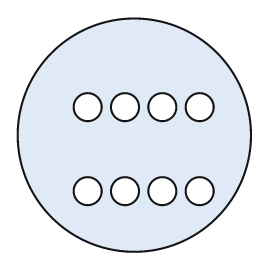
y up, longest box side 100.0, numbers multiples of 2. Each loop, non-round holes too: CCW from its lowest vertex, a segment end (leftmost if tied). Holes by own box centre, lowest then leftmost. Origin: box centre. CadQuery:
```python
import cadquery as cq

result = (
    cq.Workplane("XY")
    .moveTo(0.0, 0.0)
    .circle(50.0)
    .moveTo(-20.0, -24.0)
    .circle(6.0)
    .moveTo(-4.0, -24.0)
    .circle(6.0)
    .moveTo(12.0, -24.0)
    .circle(6.0)
    .moveTo(28.0, -24.0)
    .circle(6.0)
    .moveTo(-20.0, 12.0)
    .circle(6.0)
    .moveTo(-4.0, 12.0)
    .circle(6.0)
    .moveTo(12.0, 12.0)
    .circle(6.0)
    .moveTo(28.0, 12.0)
    .circle(6.0)
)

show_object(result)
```